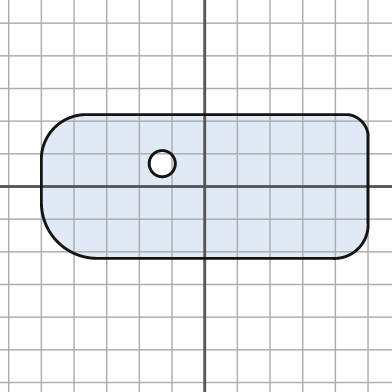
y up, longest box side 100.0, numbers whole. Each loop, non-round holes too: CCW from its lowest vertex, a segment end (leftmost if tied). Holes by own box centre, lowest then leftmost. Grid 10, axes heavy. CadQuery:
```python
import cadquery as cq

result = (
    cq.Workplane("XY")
    .moveTo(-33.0, -22.0)
    .lineTo(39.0, -22.0)
    .threePointArc((47.0, -19.0), (50.0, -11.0))
    .lineTo(50.0, 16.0)
    .threePointArc((48.0, 20.0), (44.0, 22.0))
    .lineTo(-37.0, 22.0)
    .threePointArc((-46.0, 18.0), (-50.0, 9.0))
    .lineTo(-50.0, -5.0)
    .threePointArc((-45.0, -17.0), (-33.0, -22.0))
    .close()
    .moveTo(-13.0, 7.0)
    .circle(4.0)
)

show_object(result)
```